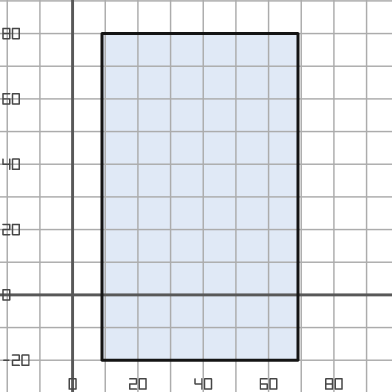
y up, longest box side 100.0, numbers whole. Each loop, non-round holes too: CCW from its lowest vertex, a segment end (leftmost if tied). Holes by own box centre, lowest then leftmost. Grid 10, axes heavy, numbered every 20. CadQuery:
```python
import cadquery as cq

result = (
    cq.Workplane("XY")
    .moveTo(9.0, -20.0)
    .lineTo(69.0, -20.0)
    .lineTo(69.0, 80.0)
    .lineTo(9.0, 80.0)
    .close()
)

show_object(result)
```